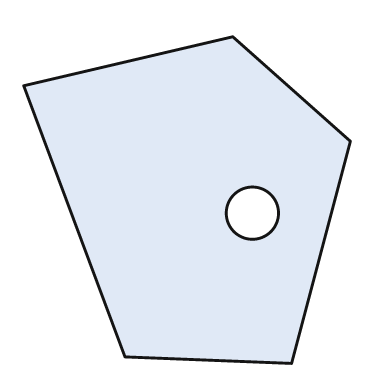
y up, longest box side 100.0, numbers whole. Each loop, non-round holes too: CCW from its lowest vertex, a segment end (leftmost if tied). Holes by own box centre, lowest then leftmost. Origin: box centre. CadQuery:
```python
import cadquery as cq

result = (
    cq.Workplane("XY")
    .moveTo(32.0, -50.0)
    .lineTo(50.0, 18.0)
    .lineTo(14.0, 50.0)
    .lineTo(-50.0, 35.0)
    .lineTo(-19.0, -48.0)
    .close()
    .moveTo(20.0, -4.0)
    .circle(8.0)
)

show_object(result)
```